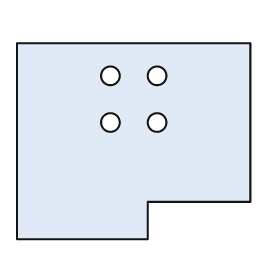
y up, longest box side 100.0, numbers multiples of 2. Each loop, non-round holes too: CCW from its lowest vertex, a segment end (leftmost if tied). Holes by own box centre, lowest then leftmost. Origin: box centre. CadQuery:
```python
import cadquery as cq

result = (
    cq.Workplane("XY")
    .moveTo(-50.0, -42.0)
    .lineTo(6.0, -42.0)
    .lineTo(6.0, -26.0)
    .lineTo(50.0, -26.0)
    .lineTo(50.0, 42.0)
    .lineTo(-50.0, 42.0)
    .close()
    .moveTo(-10.0, 8.0)
    .circle(4.0)
    .moveTo(10.0, 8.0)
    .circle(4.0)
    .moveTo(-10.0, 28.0)
    .circle(4.0)
    .moveTo(10.0, 28.0)
    .circle(4.0)
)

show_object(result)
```